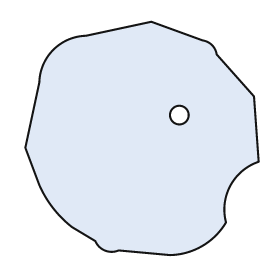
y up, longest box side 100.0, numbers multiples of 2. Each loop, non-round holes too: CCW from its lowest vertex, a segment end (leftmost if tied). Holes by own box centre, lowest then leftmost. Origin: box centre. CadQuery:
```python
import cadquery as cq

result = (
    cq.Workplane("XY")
    .moveTo(12.0, -50.0)
    .threePointArc((26.0, -46.0), (36.0, -36.0))
    .threePointArc((38.0, -20.0), (50.0, -10.0))
    .lineTo(48.0, 18.0)
    .lineTo(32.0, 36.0)
    .threePointArc((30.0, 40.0), (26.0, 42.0))
    .lineTo(4.0, 50.0)
    .lineTo(-24.0, 44.0)
    .threePointArc((-38.0, 38.0), (-44.0, 24.0))
    .lineTo(-50.0, -4.0)
    .lineTo(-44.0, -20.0)
    .threePointArc((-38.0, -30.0), (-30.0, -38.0))
    .lineTo(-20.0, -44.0)
    .threePointArc((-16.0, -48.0), (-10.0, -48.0))
    .close()
    .moveTo(16.0, 10.0)
    .circle(4.0)
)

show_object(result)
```